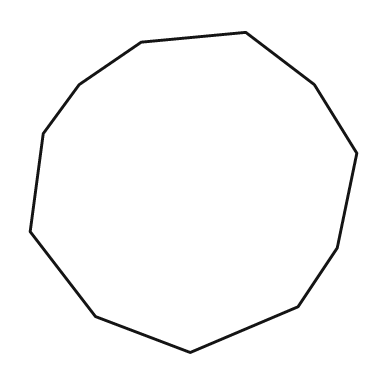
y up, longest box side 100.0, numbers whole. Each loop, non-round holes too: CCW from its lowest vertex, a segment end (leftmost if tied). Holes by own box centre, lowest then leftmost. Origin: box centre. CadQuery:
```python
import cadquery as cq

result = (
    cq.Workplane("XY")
    .moveTo(-1.0, -49.0)
    .lineTo(32.0, -35.0)
    .lineTo(44.0, -17.0)
    .lineTo(50.0, 12.0)
    .lineTo(37.0, 33.0)
    .lineTo(16.0, 49.0)
    .lineTo(-16.0, 46.0)
    .lineTo(-35.0, 33.0)
    .lineTo(-46.0, 18.0)
    .lineTo(-50.0, -12.0)
    .lineTo(-30.0, -38.0)
    .close()
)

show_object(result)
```